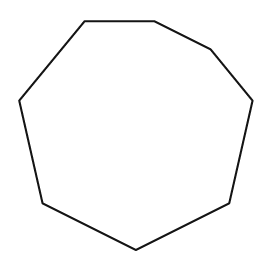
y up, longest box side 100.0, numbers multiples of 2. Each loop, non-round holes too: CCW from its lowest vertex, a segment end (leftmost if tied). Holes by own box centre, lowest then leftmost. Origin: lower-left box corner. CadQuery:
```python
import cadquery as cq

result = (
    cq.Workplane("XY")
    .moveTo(50.0, 0.0)
    .lineTo(90.0, 20.0)
    .lineTo(100.0, 64.0)
    .lineTo(82.0, 86.0)
    .lineTo(58.0, 98.0)
    .lineTo(28.0, 98.0)
    .lineTo(0.0, 64.0)
    .lineTo(10.0, 20.0)
    .close()
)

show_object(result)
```